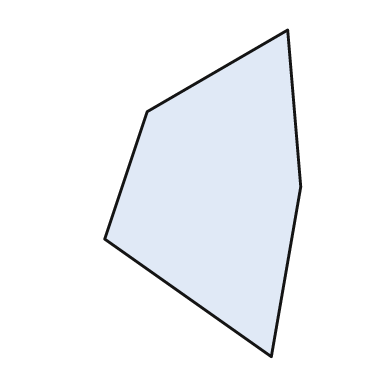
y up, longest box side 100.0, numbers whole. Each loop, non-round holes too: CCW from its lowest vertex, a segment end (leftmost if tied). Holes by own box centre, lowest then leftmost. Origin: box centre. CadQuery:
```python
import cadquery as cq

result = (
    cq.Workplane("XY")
    .moveTo(21.0, -50.0)
    .lineTo(30.0, 2.0)
    .lineTo(26.0, 50.0)
    .lineTo(-17.0, 25.0)
    .lineTo(-30.0, -14.0)
    .close()
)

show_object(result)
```